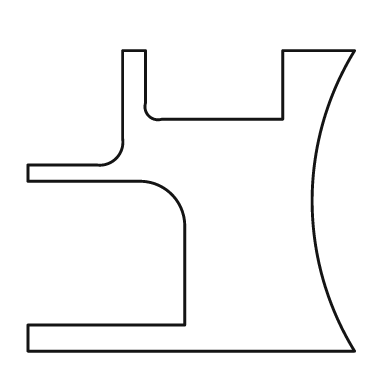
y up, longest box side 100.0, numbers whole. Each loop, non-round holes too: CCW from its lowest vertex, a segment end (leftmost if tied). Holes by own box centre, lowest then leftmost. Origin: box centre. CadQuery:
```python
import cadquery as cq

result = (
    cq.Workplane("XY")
    .moveTo(-50.0, -46.0)
    .lineTo(50.0, -46.0)
    .threePointArc((37.0, 0.0), (50.0, 46.0))
    .lineTo(28.0, 46.0)
    .lineTo(28.0, 25.0)
    .lineTo(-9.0, 25.0)
    .threePointArc((-13.0, 26.0), (-14.0, 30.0))
    .lineTo(-14.0, 46.0)
    .lineTo(-21.0, 46.0)
    .lineTo(-21.0, 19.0)
    .threePointArc((-23.0, 13.0), (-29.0, 11.0))
    .lineTo(-50.0, 11.0)
    .lineTo(-50.0, 6.0)
    .lineTo(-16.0, 6.0)
    .threePointArc((-6.0, 2.0), (-2.0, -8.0))
    .lineTo(-2.0, -38.0)
    .lineTo(-50.0, -38.0)
    .close()
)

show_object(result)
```